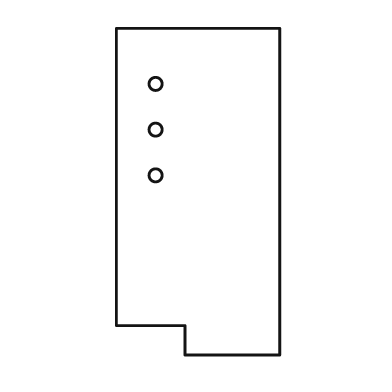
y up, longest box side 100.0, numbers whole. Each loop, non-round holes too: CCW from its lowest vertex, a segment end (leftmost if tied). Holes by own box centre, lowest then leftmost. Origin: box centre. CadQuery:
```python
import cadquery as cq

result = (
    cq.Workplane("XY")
    .moveTo(-4.0, -50.0)
    .lineTo(25.0, -50.0)
    .lineTo(25.0, 50.0)
    .lineTo(-25.0, 50.0)
    .lineTo(-25.0, -41.0)
    .lineTo(-4.0, -41.0)
    .close()
    .moveTo(-13.0, 5.0)
    .circle(2.0)
    .moveTo(-13.0, 19.0)
    .circle(2.0)
    .moveTo(-13.0, 33.0)
    .circle(2.0)
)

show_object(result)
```